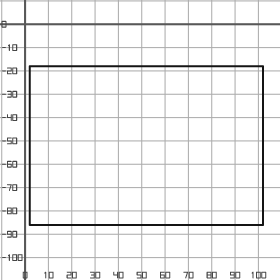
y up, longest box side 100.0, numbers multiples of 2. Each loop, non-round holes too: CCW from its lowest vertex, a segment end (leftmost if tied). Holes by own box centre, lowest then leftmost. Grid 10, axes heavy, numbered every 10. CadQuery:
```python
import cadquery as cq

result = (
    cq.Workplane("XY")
    .moveTo(2.0, -86.0)
    .lineTo(102.0, -86.0)
    .lineTo(102.0, -18.0)
    .lineTo(2.0, -18.0)
    .close()
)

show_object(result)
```